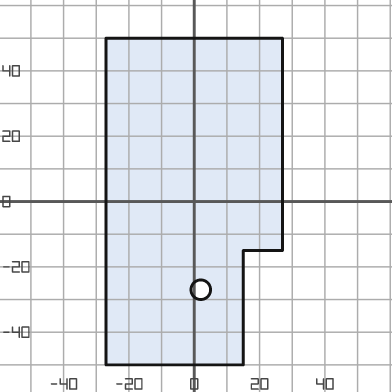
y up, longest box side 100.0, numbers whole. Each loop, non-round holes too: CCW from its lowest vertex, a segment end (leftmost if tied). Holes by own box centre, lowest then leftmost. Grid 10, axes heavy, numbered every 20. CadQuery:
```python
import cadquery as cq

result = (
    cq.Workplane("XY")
    .moveTo(-27.0, -50.0)
    .lineTo(15.0, -50.0)
    .lineTo(15.0, -15.0)
    .lineTo(27.0, -15.0)
    .lineTo(27.0, 50.0)
    .lineTo(-27.0, 50.0)
    .close()
    .moveTo(2.0, -27.0)
    .circle(3.0)
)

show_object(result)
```